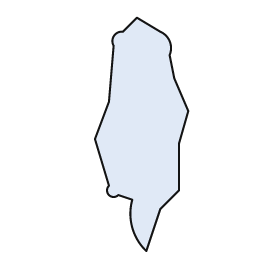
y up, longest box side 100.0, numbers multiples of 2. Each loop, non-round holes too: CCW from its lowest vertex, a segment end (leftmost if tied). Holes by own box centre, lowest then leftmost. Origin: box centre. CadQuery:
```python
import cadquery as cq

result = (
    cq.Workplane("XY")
    .moveTo(2.0, -50.0)
    .lineTo(8.0, -32.0)
    .lineTo(16.0, -24.0)
    .lineTo(16.0, -4.0)
    .lineTo(20.0, 10.0)
    .lineTo(14.0, 24.0)
    .lineTo(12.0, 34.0)
    .threePointArc((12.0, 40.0), (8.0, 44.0))
    .lineTo(-2.0, 50.0)
    .lineTo(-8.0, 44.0)
    .threePointArc((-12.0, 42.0), (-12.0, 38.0))
    .lineTo(-14.0, 14.0)
    .lineTo(-20.0, -2.0)
    .lineTo(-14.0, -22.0)
    .threePointArc((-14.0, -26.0), (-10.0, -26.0))
    .lineTo(-4.0, -28.0)
    .threePointArc((-4.0, -40.0), (2.0, -50.0))
    .close()
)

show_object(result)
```